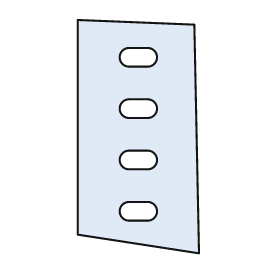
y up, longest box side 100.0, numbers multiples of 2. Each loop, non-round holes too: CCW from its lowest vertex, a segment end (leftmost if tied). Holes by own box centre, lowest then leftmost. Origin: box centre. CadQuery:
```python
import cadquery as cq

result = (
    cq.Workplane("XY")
    .moveTo(26.0, -50.0)
    .lineTo(24.0, 48.0)
    .lineTo(-26.0, 50.0)
    .lineTo(-26.0, -42.0)
    .close()
    .moveTo(-4.0, -36.0)
    .lineTo(4.0, -36.0)
    .threePointArc((8.0, -32.0), (4.0, -28.0))
    .lineTo(-4.0, -28.0)
    .threePointArc((-8.0, -32.0), (-4.0, -36.0))
    .close()
    .moveTo(-4.0, -14.0)
    .lineTo(4.0, -14.0)
    .threePointArc((8.0, -10.0), (4.0, -6.0))
    .lineTo(-4.0, -6.0)
    .threePointArc((-8.0, -10.0), (-4.0, -14.0))
    .close()
    .moveTo(-4.0, 8.0)
    .lineTo(4.0, 8.0)
    .threePointArc((8.0, 12.0), (4.0, 16.0))
    .lineTo(-4.0, 16.0)
    .threePointArc((-8.0, 12.0), (-4.0, 8.0))
    .close()
    .moveTo(-4.0, 30.0)
    .lineTo(4.0, 30.0)
    .threePointArc((8.0, 34.0), (4.0, 38.0))
    .lineTo(-4.0, 38.0)
    .threePointArc((-8.0, 34.0), (-4.0, 30.0))
    .close()
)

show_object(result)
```